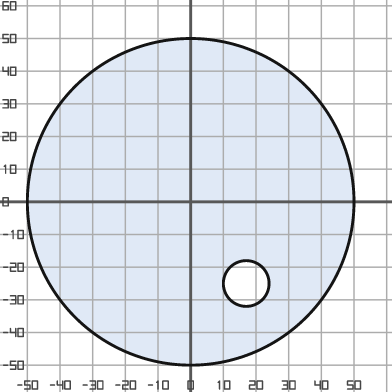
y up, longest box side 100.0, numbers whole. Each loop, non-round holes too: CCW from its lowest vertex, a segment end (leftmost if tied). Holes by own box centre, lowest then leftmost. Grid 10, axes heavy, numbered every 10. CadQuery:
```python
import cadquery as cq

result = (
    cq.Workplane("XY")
    .moveTo(0.0, 0.0)
    .circle(50.0)
    .moveTo(17.0, -25.0)
    .circle(7.0)
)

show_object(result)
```